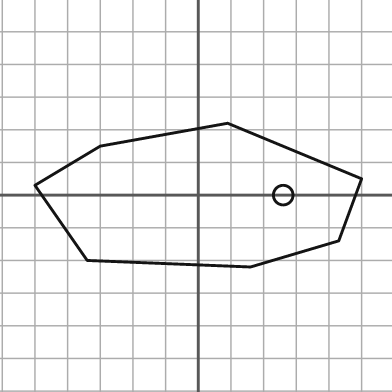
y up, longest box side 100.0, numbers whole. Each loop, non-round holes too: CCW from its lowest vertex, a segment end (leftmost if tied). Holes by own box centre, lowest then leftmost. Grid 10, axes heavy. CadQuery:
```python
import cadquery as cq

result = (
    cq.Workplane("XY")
    .moveTo(16.0, -22.0)
    .lineTo(43.0, -14.0)
    .lineTo(50.0, 5.0)
    .lineTo(9.0, 22.0)
    .lineTo(-30.0, 15.0)
    .lineTo(-50.0, 3.0)
    .lineTo(-34.0, -20.0)
    .close()
    .moveTo(26.0, 0.0)
    .circle(3.0)
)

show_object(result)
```